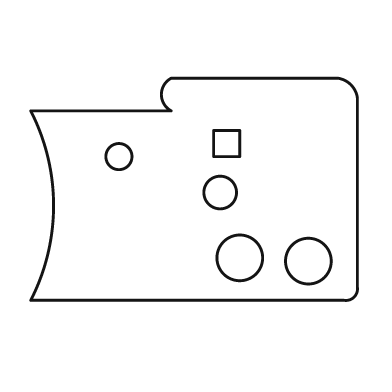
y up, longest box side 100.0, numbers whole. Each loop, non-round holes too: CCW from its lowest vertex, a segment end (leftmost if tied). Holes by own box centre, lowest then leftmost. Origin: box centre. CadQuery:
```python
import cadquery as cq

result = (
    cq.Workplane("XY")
    .moveTo(-50.0, -34.0)
    .lineTo(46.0, -34.0)
    .threePointArc((49.0, -33.0), (50.0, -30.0))
    .lineTo(50.0, 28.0)
    .threePointArc((48.0, 32.0), (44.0, 34.0))
    .lineTo(-7.0, 34.0)
    .threePointArc((-10.0, 29.0), (-7.0, 24.0))
    .lineTo(-50.0, 24.0)
    .threePointArc((-43.0, -5.0), (-50.0, -34.0))
    .close()
    .moveTo(35.0, -22.0)
    .circle(7.0)
    .moveTo(14.0, -21.0)
    .circle(7.0)
    .moveTo(8.0, -1.0)
    .circle(5.0)
    .moveTo(-23.0, 10.0)
    .circle(4.0)
    .moveTo(6.0, 10.0)
    .lineTo(14.0, 10.0)
    .lineTo(14.0, 18.0)
    .lineTo(6.0, 18.0)
    .close()
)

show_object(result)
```